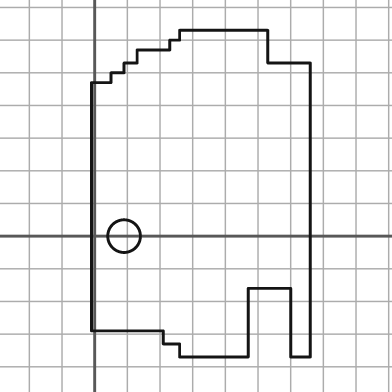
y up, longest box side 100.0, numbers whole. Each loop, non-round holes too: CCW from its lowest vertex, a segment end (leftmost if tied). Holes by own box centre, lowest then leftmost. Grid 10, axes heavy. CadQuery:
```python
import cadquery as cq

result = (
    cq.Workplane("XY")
    .moveTo(26.0, -37.0)
    .lineTo(47.0, -37.0)
    .lineTo(47.0, -16.0)
    .lineTo(60.0, -16.0)
    .lineTo(60.0, -37.0)
    .lineTo(66.0, -37.0)
    .lineTo(66.0, 53.0)
    .lineTo(53.0, 53.0)
    .lineTo(53.0, 63.0)
    .lineTo(26.0, 63.0)
    .lineTo(26.0, 60.0)
    .lineTo(23.0, 60.0)
    .lineTo(23.0, 57.0)
    .lineTo(13.0, 57.0)
    .lineTo(13.0, 53.0)
    .lineTo(9.0, 53.0)
    .lineTo(9.0, 50.0)
    .lineTo(5.0, 50.0)
    .lineTo(5.0, 47.0)
    .lineTo(-1.0, 47.0)
    .lineTo(-1.0, -29.0)
    .lineTo(21.0, -29.0)
    .lineTo(21.0, -33.0)
    .lineTo(26.0, -33.0)
    .close()
    .moveTo(9.0, 0.0)
    .circle(5.0)
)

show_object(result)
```